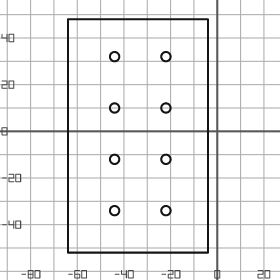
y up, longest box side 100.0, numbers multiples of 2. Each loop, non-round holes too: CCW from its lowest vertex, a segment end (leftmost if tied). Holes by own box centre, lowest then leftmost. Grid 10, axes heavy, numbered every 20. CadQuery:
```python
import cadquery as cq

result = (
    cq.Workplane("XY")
    .moveTo(-64.0, -52.0)
    .lineTo(-4.0, -52.0)
    .lineTo(-4.0, 48.0)
    .lineTo(-64.0, 48.0)
    .close()
    .moveTo(-44.0, -34.0)
    .circle(2.0)
    .moveTo(-22.0, -34.0)
    .circle(2.0)
    .moveTo(-44.0, -12.0)
    .circle(2.0)
    .moveTo(-22.0, -12.0)
    .circle(2.0)
    .moveTo(-44.0, 10.0)
    .circle(2.0)
    .moveTo(-22.0, 10.0)
    .circle(2.0)
    .moveTo(-44.0, 32.0)
    .circle(2.0)
    .moveTo(-22.0, 32.0)
    .circle(2.0)
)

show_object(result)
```